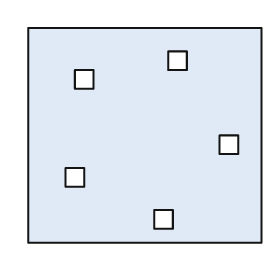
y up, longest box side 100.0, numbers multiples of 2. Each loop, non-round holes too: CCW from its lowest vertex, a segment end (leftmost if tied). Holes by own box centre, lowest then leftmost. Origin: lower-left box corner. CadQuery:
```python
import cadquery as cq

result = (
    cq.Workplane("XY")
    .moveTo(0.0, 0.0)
    .lineTo(100.0, 0.0)
    .lineTo(100.0, 92.0)
    .lineTo(0.0, 92.0)
    .close()
    .moveTo(54.0, 6.0)
    .lineTo(62.0, 6.0)
    .lineTo(62.0, 14.0)
    .lineTo(54.0, 14.0)
    .close()
    .moveTo(16.0, 24.0)
    .lineTo(24.0, 24.0)
    .lineTo(24.0, 32.0)
    .lineTo(16.0, 32.0)
    .close()
    .moveTo(82.0, 38.0)
    .lineTo(90.0, 38.0)
    .lineTo(90.0, 46.0)
    .lineTo(82.0, 46.0)
    .close()
    .moveTo(20.0, 66.0)
    .lineTo(28.0, 66.0)
    .lineTo(28.0, 74.0)
    .lineTo(20.0, 74.0)
    .close()
    .moveTo(60.0, 74.0)
    .lineTo(68.0, 74.0)
    .lineTo(68.0, 82.0)
    .lineTo(60.0, 82.0)
    .close()
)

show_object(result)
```